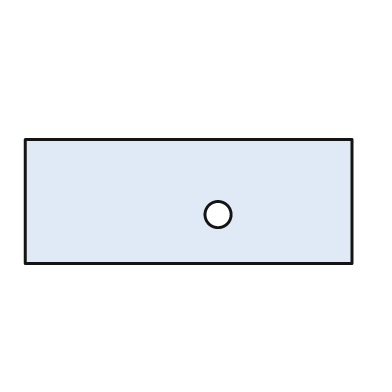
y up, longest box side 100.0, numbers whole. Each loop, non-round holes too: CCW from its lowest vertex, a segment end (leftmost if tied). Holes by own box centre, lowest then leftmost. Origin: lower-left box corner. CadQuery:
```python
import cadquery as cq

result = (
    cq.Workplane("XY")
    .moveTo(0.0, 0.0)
    .lineTo(100.0, 0.0)
    .lineTo(100.0, 38.0)
    .lineTo(0.0, 38.0)
    .close()
    .moveTo(59.0, 15.0)
    .circle(4.0)
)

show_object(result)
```